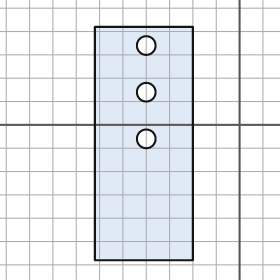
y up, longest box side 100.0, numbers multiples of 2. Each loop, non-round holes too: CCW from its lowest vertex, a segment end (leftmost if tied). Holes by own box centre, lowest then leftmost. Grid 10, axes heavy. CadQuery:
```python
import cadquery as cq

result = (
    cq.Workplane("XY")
    .moveTo(-62.0, -58.0)
    .lineTo(-20.0, -58.0)
    .lineTo(-20.0, 42.0)
    .lineTo(-62.0, 42.0)
    .close()
    .moveTo(-40.0, -6.0)
    .circle(4.0)
    .moveTo(-40.0, 14.0)
    .circle(4.0)
    .moveTo(-40.0, 34.0)
    .circle(4.0)
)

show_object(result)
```